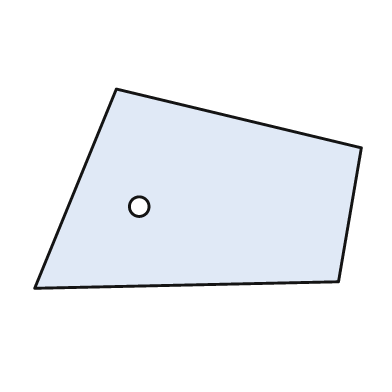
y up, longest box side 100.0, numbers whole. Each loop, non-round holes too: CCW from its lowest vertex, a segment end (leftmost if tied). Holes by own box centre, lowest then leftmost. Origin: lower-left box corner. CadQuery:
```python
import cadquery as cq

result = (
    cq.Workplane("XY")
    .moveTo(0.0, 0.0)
    .lineTo(93.0, 2.0)
    .lineTo(100.0, 43.0)
    .lineTo(25.0, 61.0)
    .close()
    .moveTo(32.0, 25.0)
    .circle(3.0)
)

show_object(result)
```